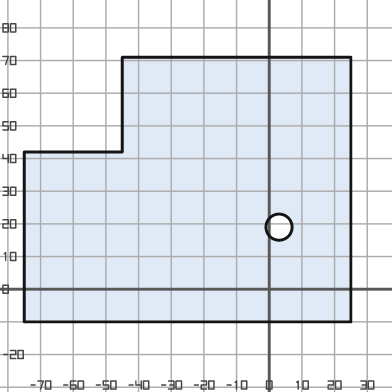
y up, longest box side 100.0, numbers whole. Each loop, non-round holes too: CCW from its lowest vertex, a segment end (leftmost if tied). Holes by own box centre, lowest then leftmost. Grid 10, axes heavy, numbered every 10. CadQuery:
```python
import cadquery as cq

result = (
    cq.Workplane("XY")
    .moveTo(-75.0, -10.0)
    .lineTo(25.0, -10.0)
    .lineTo(25.0, 71.0)
    .lineTo(-45.0, 71.0)
    .lineTo(-45.0, 42.0)
    .lineTo(-75.0, 42.0)
    .close()
    .moveTo(3.0, 19.0)
    .circle(4.0)
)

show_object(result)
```